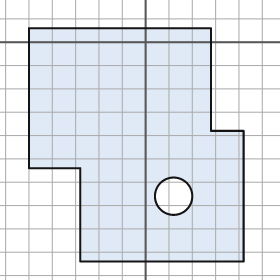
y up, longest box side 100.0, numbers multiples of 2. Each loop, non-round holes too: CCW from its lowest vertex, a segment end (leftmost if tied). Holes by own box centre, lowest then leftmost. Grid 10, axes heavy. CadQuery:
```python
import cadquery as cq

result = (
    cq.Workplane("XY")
    .moveTo(-28.0, -94.0)
    .lineTo(42.0, -94.0)
    .lineTo(42.0, -38.0)
    .lineTo(28.0, -38.0)
    .lineTo(28.0, 6.0)
    .lineTo(-50.0, 6.0)
    .lineTo(-50.0, -54.0)
    .lineTo(-28.0, -54.0)
    .close()
    .moveTo(12.0, -66.0)
    .circle(8.0)
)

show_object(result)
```